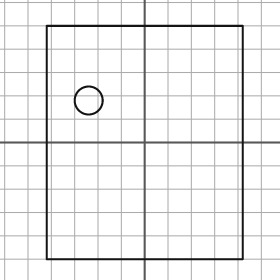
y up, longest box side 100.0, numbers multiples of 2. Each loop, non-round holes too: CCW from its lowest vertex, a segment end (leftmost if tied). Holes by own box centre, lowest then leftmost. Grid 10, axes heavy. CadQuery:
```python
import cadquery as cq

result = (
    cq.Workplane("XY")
    .moveTo(-42.0, -50.0)
    .lineTo(42.0, -50.0)
    .lineTo(42.0, 50.0)
    .lineTo(-42.0, 50.0)
    .close()
    .moveTo(-24.0, 18.0)
    .circle(6.0)
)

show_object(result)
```